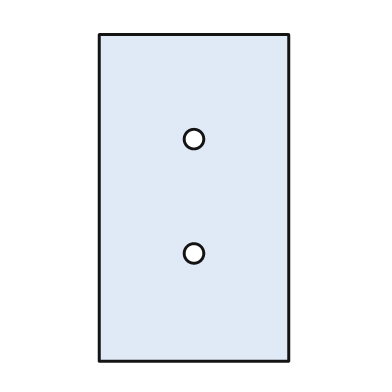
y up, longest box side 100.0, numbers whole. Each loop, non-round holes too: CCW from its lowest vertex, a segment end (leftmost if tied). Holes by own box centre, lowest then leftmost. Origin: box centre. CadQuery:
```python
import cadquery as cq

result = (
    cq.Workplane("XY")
    .moveTo(-29.0, -50.0)
    .lineTo(29.0, -50.0)
    .lineTo(29.0, 50.0)
    .lineTo(-29.0, 50.0)
    .close()
    .moveTo(0.0, -17.0)
    .circle(3.0)
    .moveTo(0.0, 18.0)
    .circle(3.0)
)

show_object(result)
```